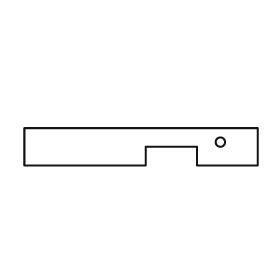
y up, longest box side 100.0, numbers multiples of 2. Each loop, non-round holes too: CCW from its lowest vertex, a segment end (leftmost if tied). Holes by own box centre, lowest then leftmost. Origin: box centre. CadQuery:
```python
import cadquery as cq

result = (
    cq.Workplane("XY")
    .moveTo(-50.0, -8.0)
    .lineTo(2.0, -8.0)
    .lineTo(2.0, 0.0)
    .lineTo(24.0, 0.0)
    .lineTo(24.0, -8.0)
    .lineTo(50.0, -8.0)
    .lineTo(50.0, 8.0)
    .lineTo(-50.0, 8.0)
    .close()
    .moveTo(34.0, 2.0)
    .circle(2.0)
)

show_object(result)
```